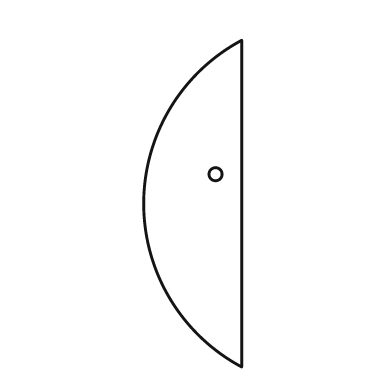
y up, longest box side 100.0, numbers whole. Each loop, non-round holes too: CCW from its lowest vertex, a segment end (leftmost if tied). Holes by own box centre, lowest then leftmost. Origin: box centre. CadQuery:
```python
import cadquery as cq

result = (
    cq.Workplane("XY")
    .moveTo(15.0, -50.0)
    .lineTo(15.0, 50.0)
    .threePointArc((-15.0, 0.0), (15.0, -50.0))
    .close()
    .moveTo(7.0, 9.0)
    .circle(2.0)
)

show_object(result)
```